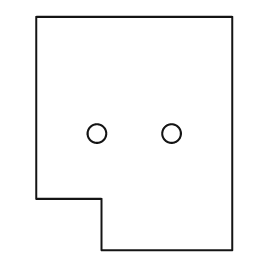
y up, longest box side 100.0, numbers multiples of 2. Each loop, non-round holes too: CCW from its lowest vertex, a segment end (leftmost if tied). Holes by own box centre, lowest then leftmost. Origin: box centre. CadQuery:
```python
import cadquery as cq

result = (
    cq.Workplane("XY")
    .moveTo(-14.0, -50.0)
    .lineTo(42.0, -50.0)
    .lineTo(42.0, 50.0)
    .lineTo(-42.0, 50.0)
    .lineTo(-42.0, -28.0)
    .lineTo(-14.0, -28.0)
    .close()
    .moveTo(-16.0, 0.0)
    .circle(4.0)
    .moveTo(16.0, 0.0)
    .circle(4.0)
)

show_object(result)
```